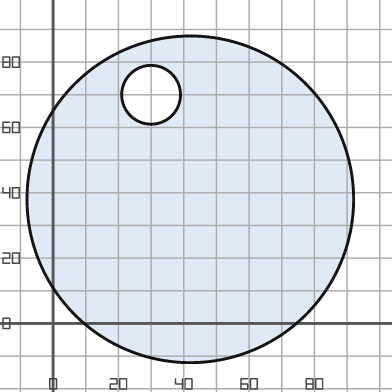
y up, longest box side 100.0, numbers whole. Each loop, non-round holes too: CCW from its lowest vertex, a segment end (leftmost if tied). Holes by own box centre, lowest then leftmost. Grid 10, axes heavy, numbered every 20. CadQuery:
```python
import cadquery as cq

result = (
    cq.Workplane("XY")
    .moveTo(42.0, 38.0)
    .circle(50.0)
    .moveTo(30.0, 70.0)
    .circle(9.0)
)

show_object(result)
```